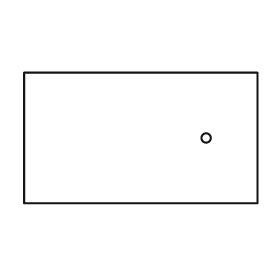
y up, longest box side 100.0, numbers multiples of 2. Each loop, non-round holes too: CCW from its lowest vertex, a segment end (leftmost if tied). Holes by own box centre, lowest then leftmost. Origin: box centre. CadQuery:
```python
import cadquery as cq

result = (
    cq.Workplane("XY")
    .moveTo(-50.0, -28.0)
    .lineTo(50.0, -28.0)
    .lineTo(50.0, 28.0)
    .lineTo(-50.0, 28.0)
    .close()
    .moveTo(28.0, 0.0)
    .circle(2.0)
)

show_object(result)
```